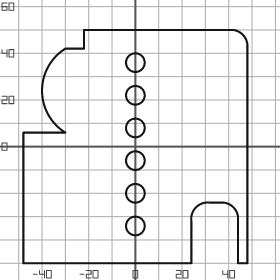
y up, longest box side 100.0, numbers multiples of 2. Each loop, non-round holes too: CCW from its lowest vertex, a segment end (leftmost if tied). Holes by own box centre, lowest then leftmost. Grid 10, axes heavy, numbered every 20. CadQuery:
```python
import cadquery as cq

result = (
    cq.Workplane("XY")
    .moveTo(-48.0, -50.0)
    .lineTo(24.0, -50.0)
    .lineTo(24.0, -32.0)
    .threePointArc((26.0, -26.0), (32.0, -24.0))
    .lineTo(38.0, -24.0)
    .threePointArc((42.0, -26.0), (44.0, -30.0))
    .lineTo(44.0, -50.0)
    .lineTo(48.0, -50.0)
    .lineTo(48.0, 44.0)
    .threePointArc((46.0, 48.0), (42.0, 50.0))
    .lineTo(-22.0, 50.0)
    .lineTo(-22.0, 42.0)
    .lineTo(-30.0, 42.0)
    .threePointArc((-40.0, 24.0), (-30.0, 6.0))
    .lineTo(-48.0, 6.0)
    .close()
    .moveTo(0.0, -34.0)
    .circle(4.0)
    .moveTo(0.0, -20.0)
    .circle(4.0)
    .moveTo(0.0, -6.0)
    .circle(4.0)
    .moveTo(0.0, 8.0)
    .circle(4.0)
    .moveTo(0.0, 22.0)
    .circle(4.0)
    .moveTo(0.0, 36.0)
    .circle(4.0)
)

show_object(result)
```